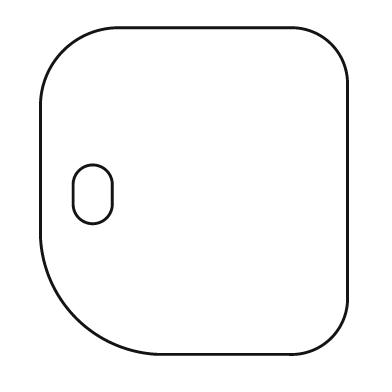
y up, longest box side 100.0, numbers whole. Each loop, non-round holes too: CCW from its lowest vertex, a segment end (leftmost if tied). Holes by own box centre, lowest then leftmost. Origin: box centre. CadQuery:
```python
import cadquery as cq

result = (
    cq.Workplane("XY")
    .moveTo(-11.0, -50.0)
    .lineTo(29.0, -50.0)
    .threePointArc((42.0, -45.0), (47.0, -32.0))
    .lineTo(47.0, 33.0)
    .threePointArc((42.0, 45.0), (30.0, 50.0))
    .lineTo(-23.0, 50.0)
    .threePointArc((-40.0, 43.0), (-47.0, 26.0))
    .lineTo(-47.0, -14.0)
    .threePointArc((-36.0, -39.0), (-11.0, -50.0))
    .close()
    .moveTo(-37.0, -4.0)
    .threePointArc((-31.0, -10.0), (-25.0, -4.0))
    .lineTo(-25.0, 2.0)
    .threePointArc((-31.0, 8.0), (-37.0, 2.0))
    .close()
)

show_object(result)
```